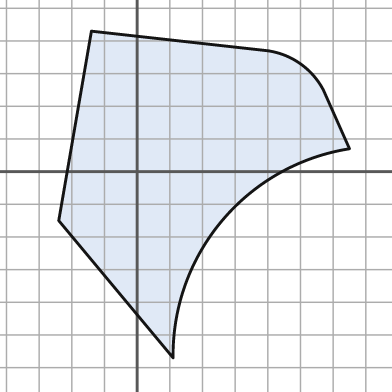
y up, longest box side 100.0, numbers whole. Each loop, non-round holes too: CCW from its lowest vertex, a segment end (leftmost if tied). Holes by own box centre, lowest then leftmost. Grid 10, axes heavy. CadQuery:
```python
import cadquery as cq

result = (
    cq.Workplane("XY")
    .moveTo(11.0, -57.0)
    .threePointArc((26.0, -15.0), (65.0, 7.0))
    .lineTo(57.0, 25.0)
    .threePointArc((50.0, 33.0), (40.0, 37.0))
    .lineTo(-14.0, 43.0)
    .lineTo(-24.0, -15.0)
    .close()
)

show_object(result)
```